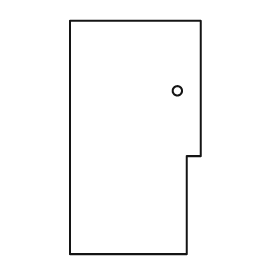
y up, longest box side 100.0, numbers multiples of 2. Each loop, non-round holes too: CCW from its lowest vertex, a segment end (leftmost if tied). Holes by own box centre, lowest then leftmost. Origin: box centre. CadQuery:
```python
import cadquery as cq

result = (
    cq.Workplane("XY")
    .moveTo(-28.0, -50.0)
    .lineTo(22.0, -50.0)
    .lineTo(22.0, -8.0)
    .lineTo(28.0, -8.0)
    .lineTo(28.0, 50.0)
    .lineTo(-28.0, 50.0)
    .close()
    .moveTo(18.0, 20.0)
    .circle(2.0)
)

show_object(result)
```